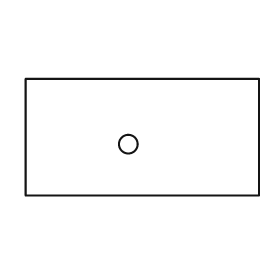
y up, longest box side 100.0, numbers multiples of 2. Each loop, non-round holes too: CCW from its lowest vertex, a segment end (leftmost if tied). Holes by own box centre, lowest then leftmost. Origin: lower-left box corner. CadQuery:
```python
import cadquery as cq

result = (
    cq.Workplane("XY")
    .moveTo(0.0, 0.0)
    .lineTo(100.0, 0.0)
    .lineTo(100.0, 50.0)
    .lineTo(0.0, 50.0)
    .close()
    .moveTo(44.0, 22.0)
    .circle(4.0)
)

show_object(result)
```